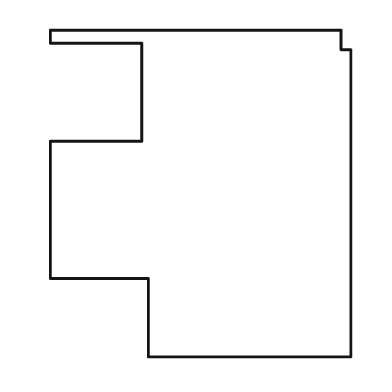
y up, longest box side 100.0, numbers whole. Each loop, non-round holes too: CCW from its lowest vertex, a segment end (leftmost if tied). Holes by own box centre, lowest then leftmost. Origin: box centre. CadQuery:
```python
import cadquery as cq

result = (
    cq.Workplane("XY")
    .moveTo(-16.0, -50.0)
    .lineTo(46.0, -50.0)
    .lineTo(46.0, 44.0)
    .lineTo(43.0, 44.0)
    .lineTo(43.0, 50.0)
    .lineTo(-46.0, 50.0)
    .lineTo(-46.0, 46.0)
    .lineTo(-18.0, 46.0)
    .lineTo(-18.0, 16.0)
    .lineTo(-46.0, 16.0)
    .lineTo(-46.0, -26.0)
    .lineTo(-16.0, -26.0)
    .close()
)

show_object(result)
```